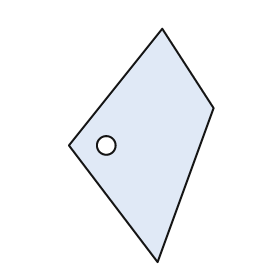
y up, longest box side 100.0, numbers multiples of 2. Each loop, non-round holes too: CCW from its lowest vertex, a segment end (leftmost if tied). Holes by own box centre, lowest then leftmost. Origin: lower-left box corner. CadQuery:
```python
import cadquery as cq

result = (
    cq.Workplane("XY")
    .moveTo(38.0, 0.0)
    .lineTo(62.0, 66.0)
    .lineTo(40.0, 100.0)
    .lineTo(0.0, 50.0)
    .close()
    .moveTo(16.0, 50.0)
    .circle(4.0)
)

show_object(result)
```